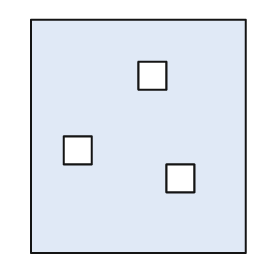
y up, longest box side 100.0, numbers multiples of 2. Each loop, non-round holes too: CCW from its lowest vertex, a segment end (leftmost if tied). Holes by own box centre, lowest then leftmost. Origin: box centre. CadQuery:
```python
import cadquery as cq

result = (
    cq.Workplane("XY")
    .moveTo(-46.0, -50.0)
    .lineTo(46.0, -50.0)
    .lineTo(46.0, 50.0)
    .lineTo(-46.0, 50.0)
    .close()
    .moveTo(12.0, -24.0)
    .lineTo(24.0, -24.0)
    .lineTo(24.0, -12.0)
    .lineTo(12.0, -12.0)
    .close()
    .moveTo(-32.0, -12.0)
    .lineTo(-20.0, -12.0)
    .lineTo(-20.0, 0.0)
    .lineTo(-32.0, 0.0)
    .close()
    .moveTo(0.0, 20.0)
    .lineTo(12.0, 20.0)
    .lineTo(12.0, 32.0)
    .lineTo(0.0, 32.0)
    .close()
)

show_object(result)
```